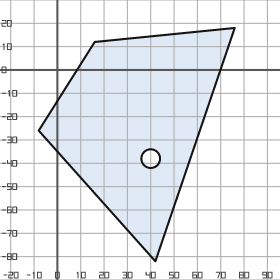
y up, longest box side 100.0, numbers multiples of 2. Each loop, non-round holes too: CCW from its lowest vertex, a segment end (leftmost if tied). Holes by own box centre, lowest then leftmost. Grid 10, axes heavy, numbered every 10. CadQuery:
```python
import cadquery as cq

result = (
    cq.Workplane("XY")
    .moveTo(42.0, -82.0)
    .lineTo(76.0, 18.0)
    .lineTo(16.0, 12.0)
    .lineTo(-8.0, -26.0)
    .close()
    .moveTo(40.0, -38.0)
    .circle(4.0)
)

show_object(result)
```